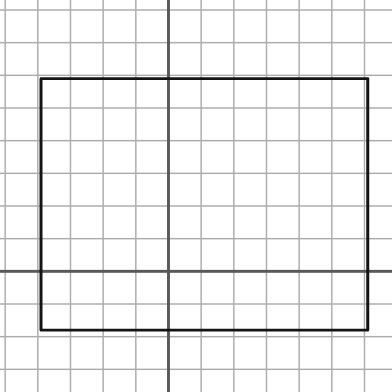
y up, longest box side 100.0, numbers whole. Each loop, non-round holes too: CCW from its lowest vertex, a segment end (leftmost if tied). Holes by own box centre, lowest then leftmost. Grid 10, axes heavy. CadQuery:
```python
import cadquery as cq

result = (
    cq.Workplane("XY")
    .moveTo(-39.0, -18.0)
    .lineTo(61.0, -18.0)
    .lineTo(61.0, 59.0)
    .lineTo(-39.0, 59.0)
    .close()
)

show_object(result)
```